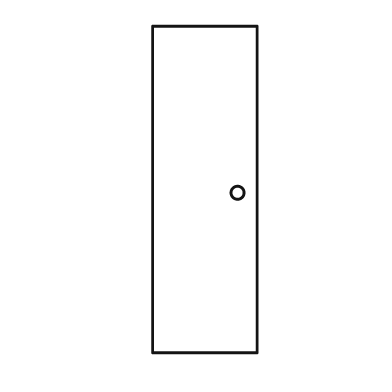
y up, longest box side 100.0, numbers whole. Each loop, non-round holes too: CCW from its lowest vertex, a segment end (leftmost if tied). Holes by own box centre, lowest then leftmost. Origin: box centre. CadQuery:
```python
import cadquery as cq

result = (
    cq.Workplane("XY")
    .moveTo(-16.0, -50.0)
    .lineTo(16.0, -50.0)
    .lineTo(16.0, 50.0)
    .lineTo(-16.0, 50.0)
    .close()
    .moveTo(10.0, -1.0)
    .circle(2.0)
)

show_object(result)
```